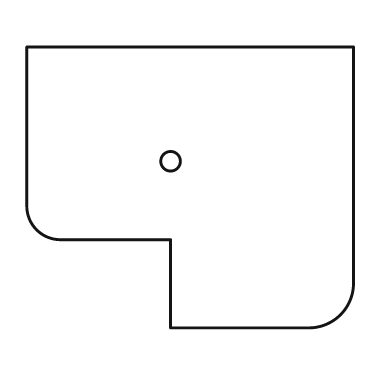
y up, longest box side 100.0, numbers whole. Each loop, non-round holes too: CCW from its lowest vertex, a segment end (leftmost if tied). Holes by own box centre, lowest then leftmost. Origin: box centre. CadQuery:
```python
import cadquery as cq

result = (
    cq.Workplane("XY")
    .moveTo(-6.0, -43.0)
    .lineTo(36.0, -43.0)
    .threePointArc((46.0, -39.0), (50.0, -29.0))
    .lineTo(50.0, 43.0)
    .lineTo(-50.0, 43.0)
    .lineTo(-50.0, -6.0)
    .threePointArc((-47.0, -13.0), (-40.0, -16.0))
    .lineTo(-6.0, -16.0)
    .close()
    .moveTo(-6.0, 8.0)
    .circle(3.0)
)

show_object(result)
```